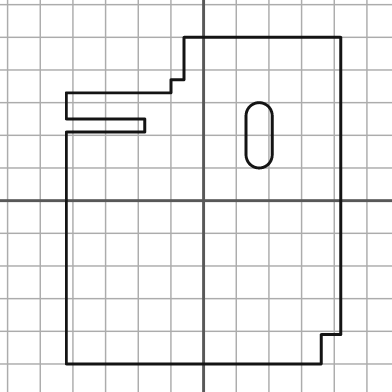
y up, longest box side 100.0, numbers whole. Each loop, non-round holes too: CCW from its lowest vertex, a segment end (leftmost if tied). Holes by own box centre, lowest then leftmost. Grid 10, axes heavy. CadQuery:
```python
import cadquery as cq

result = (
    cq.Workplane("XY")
    .moveTo(-42.0, -50.0)
    .lineTo(36.0, -50.0)
    .lineTo(36.0, -41.0)
    .lineTo(42.0, -41.0)
    .lineTo(42.0, 50.0)
    .lineTo(-6.0, 50.0)
    .lineTo(-6.0, 37.0)
    .lineTo(-10.0, 37.0)
    .lineTo(-10.0, 33.0)
    .lineTo(-42.0, 33.0)
    .lineTo(-42.0, 25.0)
    .lineTo(-18.0, 25.0)
    .lineTo(-18.0, 21.0)
    .lineTo(-42.0, 21.0)
    .close()
    .moveTo(13.0, 14.0)
    .threePointArc((17.0, 10.0), (21.0, 14.0))
    .lineTo(21.0, 26.0)
    .threePointArc((17.0, 30.0), (13.0, 26.0))
    .close()
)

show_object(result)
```